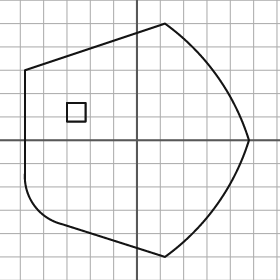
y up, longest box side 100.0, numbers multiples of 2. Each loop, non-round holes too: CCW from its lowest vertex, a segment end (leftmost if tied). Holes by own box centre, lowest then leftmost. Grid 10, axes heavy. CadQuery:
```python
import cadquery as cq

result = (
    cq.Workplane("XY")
    .moveTo(12.0, -50.0)
    .threePointArc((34.0, -28.0), (48.0, 0.0))
    .threePointArc((34.0, 28.0), (12.0, 50.0))
    .lineTo(-48.0, 30.0)
    .lineTo(-48.0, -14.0)
    .threePointArc((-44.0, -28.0), (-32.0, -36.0))
    .close()
    .moveTo(-30.0, 8.0)
    .lineTo(-22.0, 8.0)
    .lineTo(-22.0, 16.0)
    .lineTo(-30.0, 16.0)
    .close()
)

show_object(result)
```